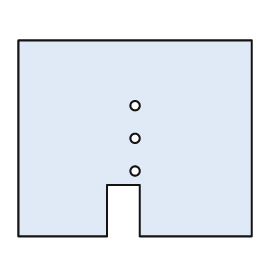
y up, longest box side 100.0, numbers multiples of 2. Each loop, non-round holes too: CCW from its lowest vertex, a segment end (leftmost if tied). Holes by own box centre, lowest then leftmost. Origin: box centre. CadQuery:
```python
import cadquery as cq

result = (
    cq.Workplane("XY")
    .moveTo(-50.0, -42.0)
    .lineTo(-12.0, -42.0)
    .lineTo(-12.0, -20.0)
    .lineTo(2.0, -20.0)
    .lineTo(2.0, -42.0)
    .lineTo(50.0, -42.0)
    .lineTo(50.0, 42.0)
    .lineTo(-50.0, 42.0)
    .close()
    .moveTo(0.0, -14.0)
    .circle(2.0)
    .moveTo(0.0, 0.0)
    .circle(2.0)
    .moveTo(0.0, 14.0)
    .circle(2.0)
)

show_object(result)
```